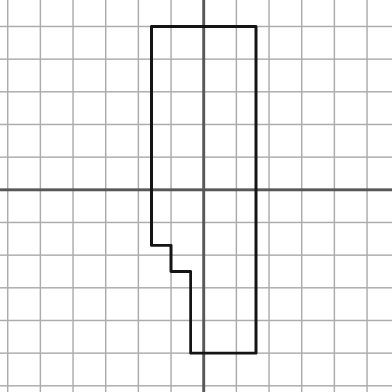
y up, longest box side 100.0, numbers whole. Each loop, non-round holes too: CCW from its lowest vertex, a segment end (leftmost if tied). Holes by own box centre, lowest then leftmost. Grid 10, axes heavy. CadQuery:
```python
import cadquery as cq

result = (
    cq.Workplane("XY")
    .moveTo(-4.0, -50.0)
    .lineTo(16.0, -50.0)
    .lineTo(16.0, 50.0)
    .lineTo(-16.0, 50.0)
    .lineTo(-16.0, -17.0)
    .lineTo(-10.0, -17.0)
    .lineTo(-10.0, -25.0)
    .lineTo(-4.0, -25.0)
    .close()
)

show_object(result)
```